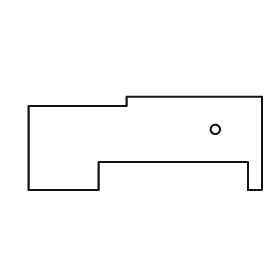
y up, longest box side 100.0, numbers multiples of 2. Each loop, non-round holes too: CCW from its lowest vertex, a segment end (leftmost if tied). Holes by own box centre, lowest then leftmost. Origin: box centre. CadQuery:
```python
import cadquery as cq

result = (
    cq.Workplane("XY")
    .moveTo(-50.0, -20.0)
    .lineTo(-20.0, -20.0)
    .lineTo(-20.0, -8.0)
    .lineTo(44.0, -8.0)
    .lineTo(44.0, -20.0)
    .lineTo(50.0, -20.0)
    .lineTo(50.0, 20.0)
    .lineTo(-8.0, 20.0)
    .lineTo(-8.0, 16.0)
    .lineTo(-50.0, 16.0)
    .close()
    .moveTo(30.0, 6.0)
    .circle(2.0)
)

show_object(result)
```